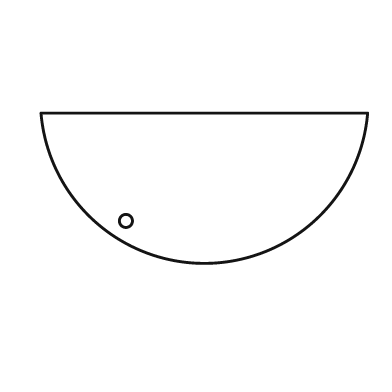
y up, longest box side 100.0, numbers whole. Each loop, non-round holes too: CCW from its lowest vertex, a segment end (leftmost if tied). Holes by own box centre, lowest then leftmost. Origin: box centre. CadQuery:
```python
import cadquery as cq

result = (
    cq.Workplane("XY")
    .moveTo(-50.0, 23.0)
    .threePointArc((0.0, -23.0), (50.0, 23.0))
    .close()
    .moveTo(-24.0, -10.0)
    .circle(2.0)
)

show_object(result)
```